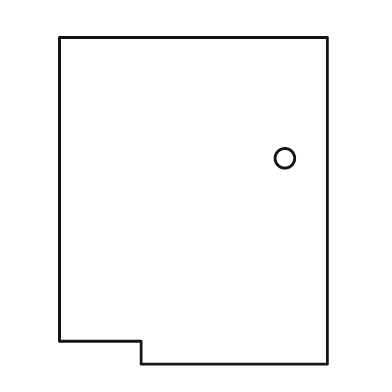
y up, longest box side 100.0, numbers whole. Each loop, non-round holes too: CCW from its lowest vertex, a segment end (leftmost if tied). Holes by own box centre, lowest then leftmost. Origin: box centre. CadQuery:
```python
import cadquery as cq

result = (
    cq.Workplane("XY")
    .moveTo(-16.0, -50.0)
    .lineTo(41.0, -50.0)
    .lineTo(41.0, 50.0)
    .lineTo(-41.0, 50.0)
    .lineTo(-41.0, -43.0)
    .lineTo(-16.0, -43.0)
    .close()
    .moveTo(28.0, 13.0)
    .circle(3.0)
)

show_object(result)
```